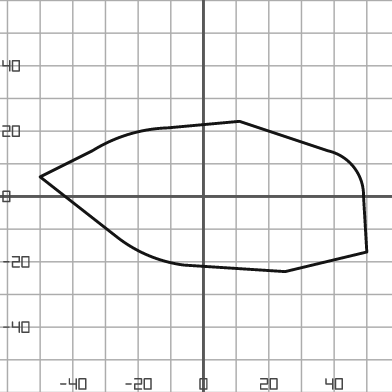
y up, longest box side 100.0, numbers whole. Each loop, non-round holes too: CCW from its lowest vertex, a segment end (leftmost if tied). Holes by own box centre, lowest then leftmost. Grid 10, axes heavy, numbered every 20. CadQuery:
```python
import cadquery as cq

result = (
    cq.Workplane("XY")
    .moveTo(25.0, -23.0)
    .lineTo(50.0, -17.0)
    .lineTo(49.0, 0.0)
    .threePointArc((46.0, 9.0), (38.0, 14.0))
    .lineTo(11.0, 23.0)
    .lineTo(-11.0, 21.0)
    .threePointArc((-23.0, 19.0), (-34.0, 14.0))
    .lineTo(-50.0, 6.0)
    .lineTo(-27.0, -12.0)
    .threePointArc((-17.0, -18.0), (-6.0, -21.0))
    .close()
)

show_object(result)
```